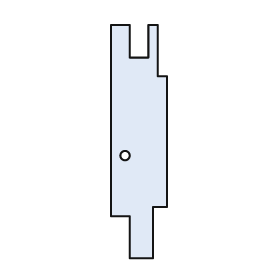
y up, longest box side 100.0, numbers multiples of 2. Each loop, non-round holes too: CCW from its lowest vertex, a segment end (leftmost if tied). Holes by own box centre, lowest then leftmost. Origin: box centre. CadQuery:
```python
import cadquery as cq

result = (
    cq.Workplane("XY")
    .moveTo(-4.0, -50.0)
    .lineTo(6.0, -50.0)
    .lineTo(6.0, -28.0)
    .lineTo(12.0, -28.0)
    .lineTo(12.0, 28.0)
    .lineTo(8.0, 28.0)
    .lineTo(8.0, 50.0)
    .lineTo(4.0, 50.0)
    .lineTo(4.0, 36.0)
    .lineTo(-4.0, 36.0)
    .lineTo(-4.0, 50.0)
    .lineTo(-12.0, 50.0)
    .lineTo(-12.0, -32.0)
    .lineTo(-4.0, -32.0)
    .close()
    .moveTo(-6.0, -6.0)
    .circle(2.0)
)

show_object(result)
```